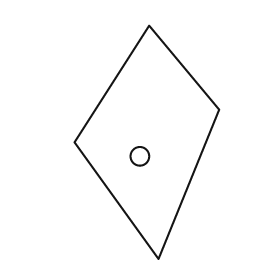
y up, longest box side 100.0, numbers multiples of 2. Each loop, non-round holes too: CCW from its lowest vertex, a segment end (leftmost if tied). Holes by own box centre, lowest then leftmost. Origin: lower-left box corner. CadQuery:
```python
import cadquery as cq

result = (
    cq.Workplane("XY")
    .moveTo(36.0, 0.0)
    .lineTo(62.0, 64.0)
    .lineTo(32.0, 100.0)
    .lineTo(0.0, 50.0)
    .close()
    .moveTo(28.0, 44.0)
    .circle(4.0)
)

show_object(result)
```